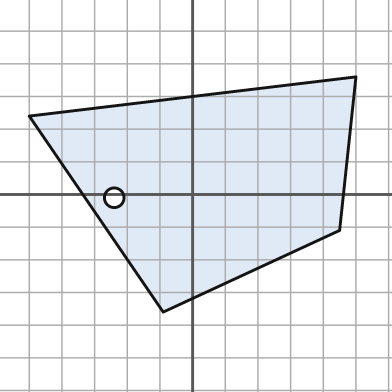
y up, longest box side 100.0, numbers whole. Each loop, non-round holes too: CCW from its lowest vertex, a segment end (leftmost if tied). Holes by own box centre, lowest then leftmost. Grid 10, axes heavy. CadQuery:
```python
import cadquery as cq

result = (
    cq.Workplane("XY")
    .moveTo(-9.0, -36.0)
    .lineTo(45.0, -11.0)
    .lineTo(50.0, 36.0)
    .lineTo(-50.0, 24.0)
    .close()
    .moveTo(-24.0, -1.0)
    .circle(3.0)
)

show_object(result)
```